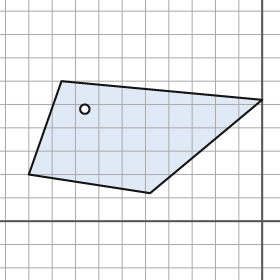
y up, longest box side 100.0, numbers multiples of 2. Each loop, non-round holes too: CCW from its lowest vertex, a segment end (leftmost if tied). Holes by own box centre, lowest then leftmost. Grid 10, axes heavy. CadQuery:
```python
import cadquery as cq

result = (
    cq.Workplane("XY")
    .moveTo(-48.0, 12.0)
    .lineTo(0.0, 52.0)
    .lineTo(-86.0, 60.0)
    .lineTo(-100.0, 20.0)
    .close()
    .moveTo(-76.0, 48.0)
    .circle(2.0)
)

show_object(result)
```